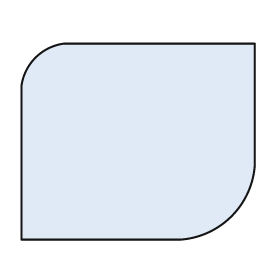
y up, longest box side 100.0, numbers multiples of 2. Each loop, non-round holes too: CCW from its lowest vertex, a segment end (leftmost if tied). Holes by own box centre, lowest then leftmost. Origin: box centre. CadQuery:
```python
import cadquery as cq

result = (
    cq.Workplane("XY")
    .moveTo(-50.0, -42.0)
    .lineTo(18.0, -42.0)
    .threePointArc((40.0, -32.0), (50.0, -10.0))
    .lineTo(50.0, 42.0)
    .lineTo(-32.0, 42.0)
    .threePointArc((-44.0, 36.0), (-50.0, 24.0))
    .close()
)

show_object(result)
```